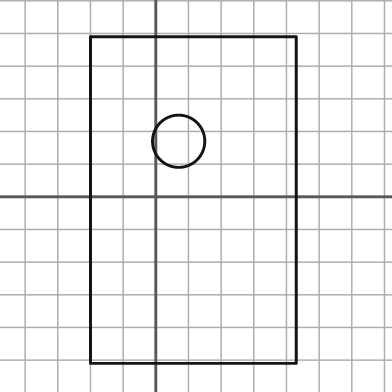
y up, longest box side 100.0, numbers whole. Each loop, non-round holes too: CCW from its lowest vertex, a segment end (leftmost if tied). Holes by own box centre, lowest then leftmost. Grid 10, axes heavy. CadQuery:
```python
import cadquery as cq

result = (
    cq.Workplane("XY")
    .moveTo(-20.0, -51.0)
    .lineTo(43.0, -51.0)
    .lineTo(43.0, 49.0)
    .lineTo(-20.0, 49.0)
    .close()
    .moveTo(7.0, 17.0)
    .circle(8.0)
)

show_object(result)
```